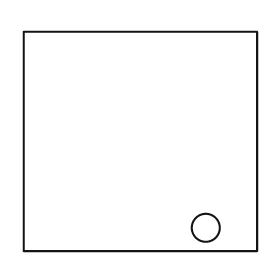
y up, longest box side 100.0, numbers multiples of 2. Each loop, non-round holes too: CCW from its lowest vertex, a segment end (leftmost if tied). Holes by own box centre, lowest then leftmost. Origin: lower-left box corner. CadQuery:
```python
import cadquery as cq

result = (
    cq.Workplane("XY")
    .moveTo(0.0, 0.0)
    .lineTo(100.0, 0.0)
    .lineTo(100.0, 94.0)
    .lineTo(0.0, 94.0)
    .close()
    .moveTo(78.0, 10.0)
    .circle(6.0)
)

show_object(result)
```